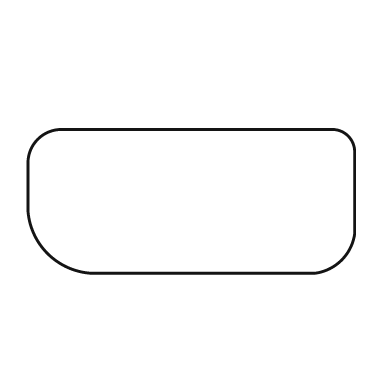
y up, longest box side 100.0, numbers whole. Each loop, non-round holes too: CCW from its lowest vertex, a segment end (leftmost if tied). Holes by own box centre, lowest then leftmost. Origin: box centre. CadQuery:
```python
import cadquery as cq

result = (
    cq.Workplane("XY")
    .moveTo(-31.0, -22.0)
    .lineTo(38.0, -22.0)
    .threePointArc((46.0, -18.0), (50.0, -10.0))
    .lineTo(50.0, 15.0)
    .threePointArc((48.0, 20.0), (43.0, 22.0))
    .lineTo(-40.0, 22.0)
    .threePointArc((-47.0, 19.0), (-50.0, 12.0))
    .lineTo(-50.0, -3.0)
    .threePointArc((-44.0, -16.0), (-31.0, -22.0))
    .close()
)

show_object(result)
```